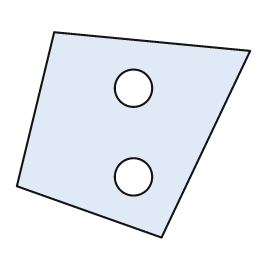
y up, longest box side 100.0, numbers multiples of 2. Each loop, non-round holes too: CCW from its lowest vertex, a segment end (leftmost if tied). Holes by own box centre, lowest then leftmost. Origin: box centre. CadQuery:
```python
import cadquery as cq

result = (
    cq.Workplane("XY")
    .moveTo(12.0, -44.0)
    .lineTo(50.0, 36.0)
    .lineTo(-34.0, 44.0)
    .lineTo(-50.0, -22.0)
    .close()
    .moveTo(0.0, -18.0)
    .circle(8.0)
    .moveTo(0.0, 20.0)
    .circle(8.0)
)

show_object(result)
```